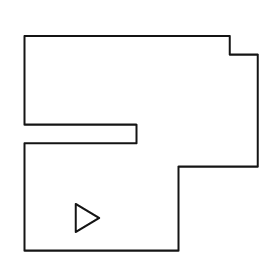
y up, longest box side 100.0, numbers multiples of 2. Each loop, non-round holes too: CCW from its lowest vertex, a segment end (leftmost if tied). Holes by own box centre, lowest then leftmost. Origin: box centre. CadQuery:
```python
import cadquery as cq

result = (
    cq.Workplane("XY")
    .moveTo(-50.0, -46.0)
    .lineTo(16.0, -46.0)
    .lineTo(16.0, -10.0)
    .lineTo(50.0, -10.0)
    .lineTo(50.0, 38.0)
    .lineTo(38.0, 38.0)
    .lineTo(38.0, 46.0)
    .lineTo(-50.0, 46.0)
    .lineTo(-50.0, 8.0)
    .lineTo(-2.0, 8.0)
    .lineTo(-2.0, 0.0)
    .lineTo(-50.0, 0.0)
    .close()
    .moveTo(-28.0, -38.0)
    .lineTo(-18.0, -32.0)
    .lineTo(-28.0, -26.0)
    .close()
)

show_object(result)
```